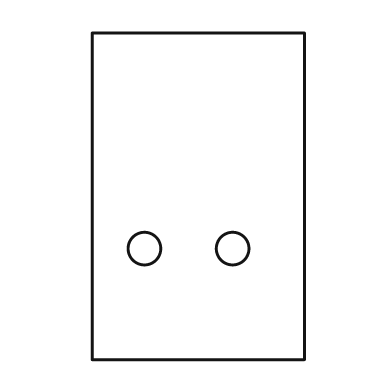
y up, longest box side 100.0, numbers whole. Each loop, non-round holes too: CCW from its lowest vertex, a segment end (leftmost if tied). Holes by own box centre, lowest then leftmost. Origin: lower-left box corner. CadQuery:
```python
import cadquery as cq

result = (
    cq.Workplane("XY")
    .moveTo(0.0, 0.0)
    .lineTo(65.0, 0.0)
    .lineTo(65.0, 100.0)
    .lineTo(0.0, 100.0)
    .close()
    .moveTo(16.0, 34.0)
    .circle(5.0)
    .moveTo(43.0, 34.0)
    .circle(5.0)
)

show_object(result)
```